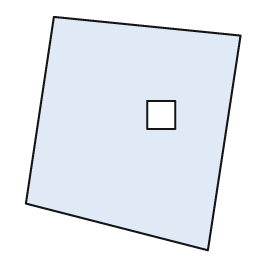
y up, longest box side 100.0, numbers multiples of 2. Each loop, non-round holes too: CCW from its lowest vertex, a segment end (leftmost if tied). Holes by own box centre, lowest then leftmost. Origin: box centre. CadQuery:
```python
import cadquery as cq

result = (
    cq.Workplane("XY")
    .moveTo(32.0, -50.0)
    .lineTo(46.0, 42.0)
    .lineTo(-34.0, 50.0)
    .lineTo(-46.0, -30.0)
    .close()
    .moveTo(6.0, 2.0)
    .lineTo(18.0, 2.0)
    .lineTo(18.0, 14.0)
    .lineTo(6.0, 14.0)
    .close()
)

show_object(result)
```